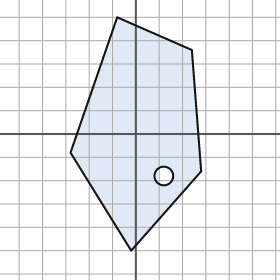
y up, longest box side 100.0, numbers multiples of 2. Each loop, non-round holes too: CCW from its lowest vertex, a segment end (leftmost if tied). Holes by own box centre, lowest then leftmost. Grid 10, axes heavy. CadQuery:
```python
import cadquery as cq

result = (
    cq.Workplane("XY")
    .moveTo(-2.0, -50.0)
    .lineTo(28.0, -16.0)
    .lineTo(24.0, 36.0)
    .lineTo(-8.0, 50.0)
    .lineTo(-28.0, -8.0)
    .close()
    .moveTo(12.0, -18.0)
    .circle(4.0)
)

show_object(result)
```